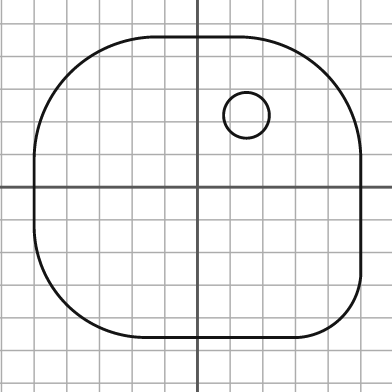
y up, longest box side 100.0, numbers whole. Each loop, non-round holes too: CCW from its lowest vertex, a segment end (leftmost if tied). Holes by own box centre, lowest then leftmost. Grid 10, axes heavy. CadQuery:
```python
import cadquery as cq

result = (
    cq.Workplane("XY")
    .moveTo(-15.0, -46.0)
    .lineTo(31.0, -46.0)
    .threePointArc((44.0, -40.0), (50.0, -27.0))
    .lineTo(50.0, 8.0)
    .threePointArc((39.0, 35.0), (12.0, 46.0))
    .lineTo(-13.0, 46.0)
    .threePointArc((-39.0, 35.0), (-50.0, 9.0))
    .lineTo(-50.0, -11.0)
    .threePointArc((-40.0, -36.0), (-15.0, -46.0))
    .close()
    .moveTo(15.0, 22.0)
    .circle(7.0)
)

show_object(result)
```